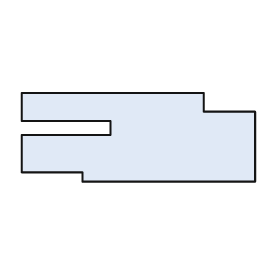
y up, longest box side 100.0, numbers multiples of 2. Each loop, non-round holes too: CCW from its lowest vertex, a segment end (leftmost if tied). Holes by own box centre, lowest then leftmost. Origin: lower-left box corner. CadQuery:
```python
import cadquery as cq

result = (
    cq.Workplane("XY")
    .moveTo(26.0, 0.0)
    .lineTo(100.0, 0.0)
    .lineTo(100.0, 30.0)
    .lineTo(78.0, 30.0)
    .lineTo(78.0, 38.0)
    .lineTo(0.0, 38.0)
    .lineTo(0.0, 26.0)
    .lineTo(38.0, 26.0)
    .lineTo(38.0, 20.0)
    .lineTo(0.0, 20.0)
    .lineTo(0.0, 4.0)
    .lineTo(26.0, 4.0)
    .close()
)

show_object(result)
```